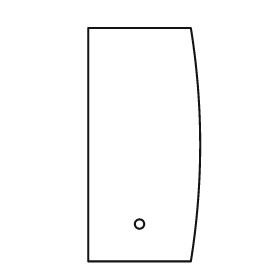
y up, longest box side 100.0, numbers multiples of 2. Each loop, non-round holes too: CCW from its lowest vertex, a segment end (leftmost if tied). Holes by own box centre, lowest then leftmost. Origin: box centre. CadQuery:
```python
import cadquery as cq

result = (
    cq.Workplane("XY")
    .moveTo(-24.0, -50.0)
    .lineTo(20.0, -50.0)
    .threePointArc((24.0, 0.0), (20.0, 50.0))
    .lineTo(-24.0, 50.0)
    .close()
    .moveTo(-2.0, -34.0)
    .circle(2.0)
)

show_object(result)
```